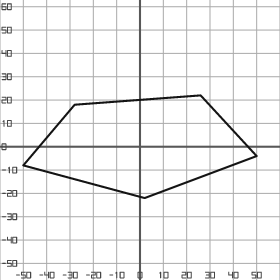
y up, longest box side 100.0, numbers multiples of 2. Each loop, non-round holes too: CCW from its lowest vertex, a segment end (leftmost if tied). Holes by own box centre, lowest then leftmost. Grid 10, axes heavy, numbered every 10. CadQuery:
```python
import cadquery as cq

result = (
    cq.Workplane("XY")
    .moveTo(2.0, -22.0)
    .lineTo(50.0, -4.0)
    .lineTo(26.0, 22.0)
    .lineTo(-28.0, 18.0)
    .lineTo(-50.0, -8.0)
    .close()
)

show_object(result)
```